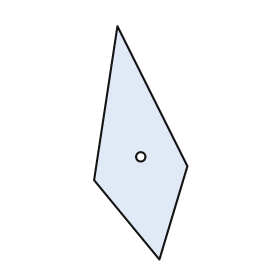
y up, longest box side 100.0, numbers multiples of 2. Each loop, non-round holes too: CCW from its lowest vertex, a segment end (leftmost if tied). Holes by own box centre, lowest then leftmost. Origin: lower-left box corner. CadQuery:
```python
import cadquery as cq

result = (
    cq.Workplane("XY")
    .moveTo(28.0, 0.0)
    .lineTo(40.0, 40.0)
    .lineTo(10.0, 100.0)
    .lineTo(0.0, 34.0)
    .close()
    .moveTo(20.0, 44.0)
    .circle(2.0)
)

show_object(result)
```